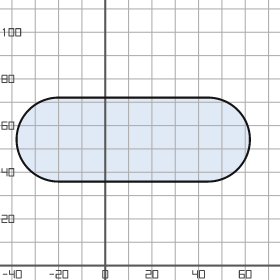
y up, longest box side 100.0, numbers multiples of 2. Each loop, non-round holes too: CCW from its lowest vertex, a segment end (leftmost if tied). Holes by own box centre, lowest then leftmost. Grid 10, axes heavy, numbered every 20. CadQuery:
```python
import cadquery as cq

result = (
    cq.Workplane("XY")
    .moveTo(-20.0, 36.0)
    .lineTo(44.0, 36.0)
    .threePointArc((62.0, 54.0), (44.0, 72.0))
    .lineTo(-20.0, 72.0)
    .threePointArc((-38.0, 54.0), (-20.0, 36.0))
    .close()
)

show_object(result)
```